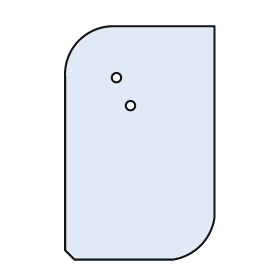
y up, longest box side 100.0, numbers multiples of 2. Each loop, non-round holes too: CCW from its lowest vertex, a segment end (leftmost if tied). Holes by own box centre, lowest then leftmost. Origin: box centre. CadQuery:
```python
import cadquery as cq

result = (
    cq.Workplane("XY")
    .moveTo(-28.0, -50.0)
    .lineTo(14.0, -50.0)
    .threePointArc((26.0, -44.0), (32.0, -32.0))
    .lineTo(32.0, 50.0)
    .lineTo(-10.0, 50.0)
    .threePointArc((-26.0, 44.0), (-32.0, 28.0))
    .lineTo(-32.0, -46.0)
    .close()
    .moveTo(-4.0, 16.0)
    .circle(2.0)
    .moveTo(-10.0, 28.0)
    .circle(2.0)
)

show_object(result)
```